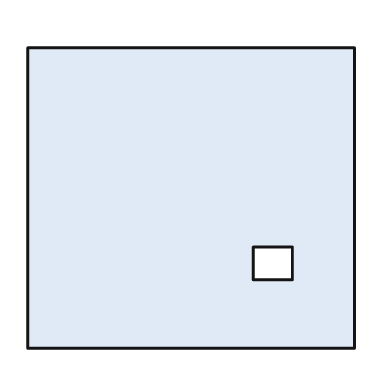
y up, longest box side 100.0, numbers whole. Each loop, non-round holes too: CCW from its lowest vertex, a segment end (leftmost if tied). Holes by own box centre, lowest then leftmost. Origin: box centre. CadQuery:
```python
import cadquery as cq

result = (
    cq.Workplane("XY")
    .moveTo(-50.0, -46.0)
    .lineTo(50.0, -46.0)
    .lineTo(50.0, 46.0)
    .lineTo(-50.0, 46.0)
    .close()
    .moveTo(19.0, -25.0)
    .lineTo(31.0, -25.0)
    .lineTo(31.0, -15.0)
    .lineTo(19.0, -15.0)
    .close()
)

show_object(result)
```